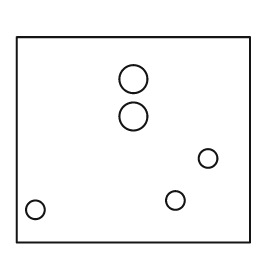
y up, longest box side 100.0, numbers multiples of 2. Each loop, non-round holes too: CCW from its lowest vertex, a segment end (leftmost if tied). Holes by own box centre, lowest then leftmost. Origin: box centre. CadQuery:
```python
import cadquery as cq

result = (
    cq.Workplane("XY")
    .moveTo(-50.0, -44.0)
    .lineTo(50.0, -44.0)
    .lineTo(50.0, 44.0)
    .lineTo(-50.0, 44.0)
    .close()
    .moveTo(-42.0, -30.0)
    .circle(4.0)
    .moveTo(18.0, -26.0)
    .circle(4.0)
    .moveTo(32.0, -8.0)
    .circle(4.0)
    .moveTo(0.0, 10.0)
    .circle(6.0)
    .moveTo(0.0, 26.0)
    .circle(6.0)
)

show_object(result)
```